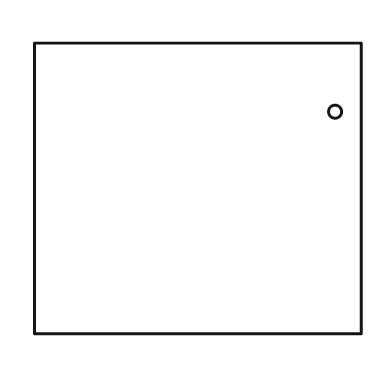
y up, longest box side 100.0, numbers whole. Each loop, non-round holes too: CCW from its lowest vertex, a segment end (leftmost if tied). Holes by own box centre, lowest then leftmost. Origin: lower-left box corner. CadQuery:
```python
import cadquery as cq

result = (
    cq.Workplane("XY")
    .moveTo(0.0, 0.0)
    .lineTo(100.0, 0.0)
    .lineTo(100.0, 89.0)
    .lineTo(0.0, 89.0)
    .close()
    .moveTo(92.0, 68.0)
    .circle(2.0)
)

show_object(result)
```